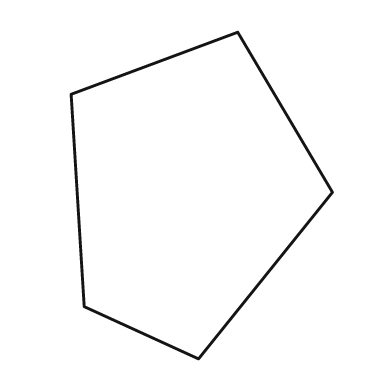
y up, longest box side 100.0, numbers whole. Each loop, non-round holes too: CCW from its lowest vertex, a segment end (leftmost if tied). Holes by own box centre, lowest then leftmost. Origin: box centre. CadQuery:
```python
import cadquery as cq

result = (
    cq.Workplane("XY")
    .moveTo(-1.0, -50.0)
    .lineTo(40.0, 1.0)
    .lineTo(11.0, 50.0)
    .lineTo(-40.0, 31.0)
    .lineTo(-36.0, -34.0)
    .close()
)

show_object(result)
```